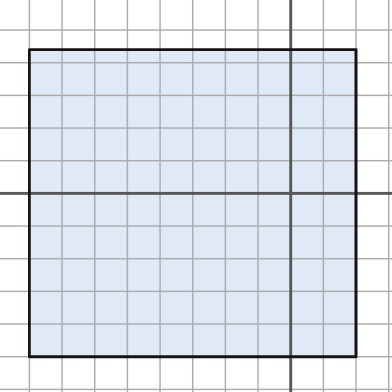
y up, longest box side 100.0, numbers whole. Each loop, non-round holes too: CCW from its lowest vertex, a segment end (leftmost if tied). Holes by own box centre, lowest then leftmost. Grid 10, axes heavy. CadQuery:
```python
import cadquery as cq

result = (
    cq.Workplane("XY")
    .moveTo(-80.0, -50.0)
    .lineTo(20.0, -50.0)
    .lineTo(20.0, 44.0)
    .lineTo(-80.0, 44.0)
    .close()
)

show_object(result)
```